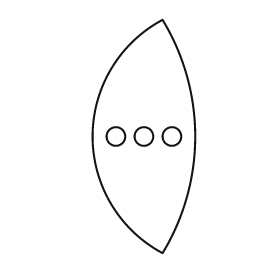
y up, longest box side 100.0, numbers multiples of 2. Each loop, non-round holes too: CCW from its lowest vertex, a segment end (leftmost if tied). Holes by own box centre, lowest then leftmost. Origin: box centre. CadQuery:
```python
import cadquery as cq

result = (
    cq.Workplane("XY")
    .moveTo(8.0, -50.0)
    .threePointArc((22.0, 0.0), (8.0, 50.0))
    .threePointArc((-22.0, 0.0), (8.0, -50.0))
    .close()
    .moveTo(-12.0, 0.0)
    .circle(4.0)
    .moveTo(0.0, 0.0)
    .circle(4.0)
    .moveTo(12.0, 0.0)
    .circle(4.0)
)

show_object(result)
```